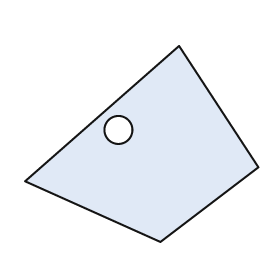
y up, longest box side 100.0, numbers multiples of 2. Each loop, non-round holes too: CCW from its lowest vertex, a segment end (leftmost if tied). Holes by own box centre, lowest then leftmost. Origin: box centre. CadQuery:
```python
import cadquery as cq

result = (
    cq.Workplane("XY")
    .moveTo(8.0, -42.0)
    .lineTo(50.0, -10.0)
    .lineTo(16.0, 42.0)
    .lineTo(-50.0, -16.0)
    .close()
    .moveTo(-10.0, 6.0)
    .circle(6.0)
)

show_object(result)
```